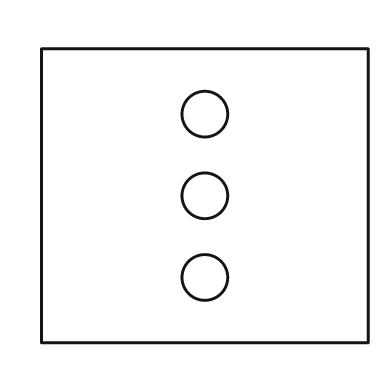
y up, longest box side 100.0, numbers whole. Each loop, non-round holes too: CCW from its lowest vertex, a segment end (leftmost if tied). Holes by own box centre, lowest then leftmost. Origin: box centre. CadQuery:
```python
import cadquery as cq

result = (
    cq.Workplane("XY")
    .moveTo(-50.0, -45.0)
    .lineTo(50.0, -45.0)
    .lineTo(50.0, 45.0)
    .lineTo(-50.0, 45.0)
    .close()
    .moveTo(0.0, -25.0)
    .circle(7.0)
    .moveTo(0.0, 0.0)
    .circle(7.0)
    .moveTo(0.0, 25.0)
    .circle(7.0)
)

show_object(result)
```